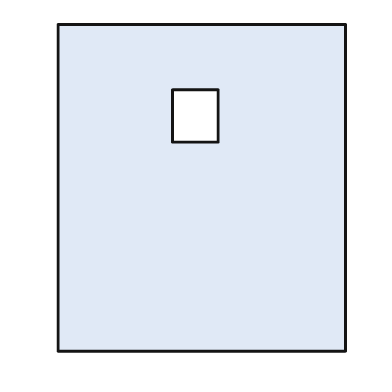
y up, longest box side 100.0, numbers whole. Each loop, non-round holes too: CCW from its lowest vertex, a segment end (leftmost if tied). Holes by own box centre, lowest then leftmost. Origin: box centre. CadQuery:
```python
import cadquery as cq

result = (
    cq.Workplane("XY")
    .moveTo(-44.0, -50.0)
    .lineTo(44.0, -50.0)
    .lineTo(44.0, 50.0)
    .lineTo(-44.0, 50.0)
    .close()
    .moveTo(-9.0, 14.0)
    .lineTo(5.0, 14.0)
    .lineTo(5.0, 30.0)
    .lineTo(-9.0, 30.0)
    .close()
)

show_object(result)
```